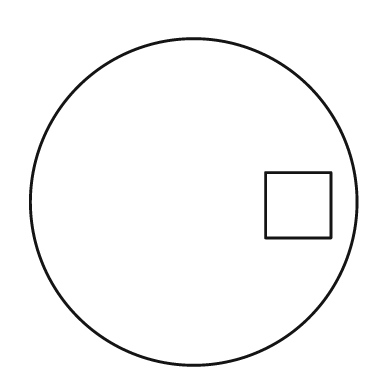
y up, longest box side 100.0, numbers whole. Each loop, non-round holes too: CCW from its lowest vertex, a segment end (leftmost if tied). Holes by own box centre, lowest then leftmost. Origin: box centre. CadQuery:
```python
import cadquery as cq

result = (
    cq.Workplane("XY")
    .moveTo(0.0, 0.0)
    .circle(50.0)
    .moveTo(22.0, -11.0)
    .lineTo(42.0, -11.0)
    .lineTo(42.0, 9.0)
    .lineTo(22.0, 9.0)
    .close()
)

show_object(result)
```